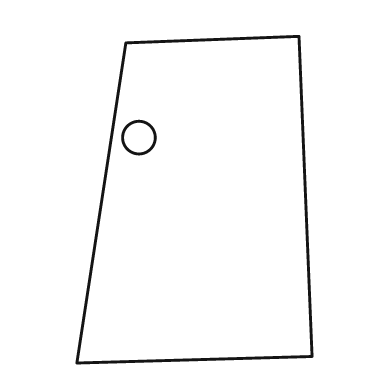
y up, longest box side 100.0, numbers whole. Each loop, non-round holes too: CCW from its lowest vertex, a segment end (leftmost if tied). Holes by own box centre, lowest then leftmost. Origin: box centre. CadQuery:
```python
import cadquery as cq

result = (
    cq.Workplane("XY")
    .moveTo(-36.0, -50.0)
    .lineTo(36.0, -48.0)
    .lineTo(32.0, 50.0)
    .lineTo(-21.0, 48.0)
    .close()
    .moveTo(-17.0, 19.0)
    .circle(5.0)
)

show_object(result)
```